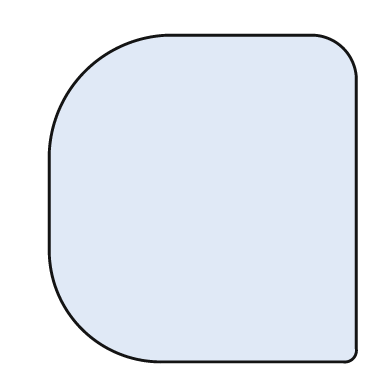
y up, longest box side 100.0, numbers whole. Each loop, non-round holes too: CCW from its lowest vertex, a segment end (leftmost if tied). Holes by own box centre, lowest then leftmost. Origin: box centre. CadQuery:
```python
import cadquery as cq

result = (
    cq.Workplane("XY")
    .moveTo(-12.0, -50.0)
    .lineTo(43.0, -50.0)
    .threePointArc((46.0, -49.0), (47.0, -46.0))
    .lineTo(47.0, 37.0)
    .threePointArc((43.0, 46.0), (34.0, 50.0))
    .lineTo(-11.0, 50.0)
    .threePointArc((-36.0, 39.0), (-47.0, 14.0))
    .lineTo(-47.0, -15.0)
    .threePointArc((-37.0, -40.0), (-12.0, -50.0))
    .close()
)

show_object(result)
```